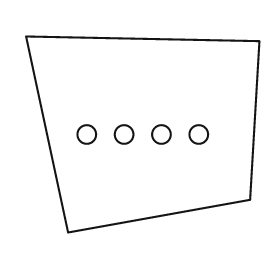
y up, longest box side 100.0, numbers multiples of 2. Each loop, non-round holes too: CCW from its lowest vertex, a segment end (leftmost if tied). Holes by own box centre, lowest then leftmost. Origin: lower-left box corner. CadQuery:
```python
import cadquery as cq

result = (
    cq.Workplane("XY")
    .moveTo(18.0, 0.0)
    .lineTo(96.0, 14.0)
    .lineTo(100.0, 82.0)
    .lineTo(0.0, 84.0)
    .close()
    .moveTo(26.0, 42.0)
    .circle(4.0)
    .moveTo(42.0, 42.0)
    .circle(4.0)
    .moveTo(58.0, 42.0)
    .circle(4.0)
    .moveTo(74.0, 42.0)
    .circle(4.0)
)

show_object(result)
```